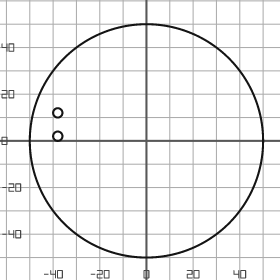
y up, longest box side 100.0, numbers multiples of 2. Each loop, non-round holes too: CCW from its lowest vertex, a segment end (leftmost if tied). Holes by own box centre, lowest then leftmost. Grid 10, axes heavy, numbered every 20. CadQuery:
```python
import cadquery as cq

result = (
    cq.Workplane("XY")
    .moveTo(0.0, 0.0)
    .circle(50.0)
    .moveTo(-38.0, 2.0)
    .circle(2.0)
    .moveTo(-38.0, 12.0)
    .circle(2.0)
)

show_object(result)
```